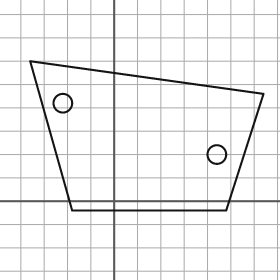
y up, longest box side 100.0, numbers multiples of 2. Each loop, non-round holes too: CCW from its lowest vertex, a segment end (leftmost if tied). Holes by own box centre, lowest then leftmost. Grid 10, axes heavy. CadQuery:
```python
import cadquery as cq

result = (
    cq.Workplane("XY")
    .moveTo(-18.0, -4.0)
    .lineTo(48.0, -4.0)
    .lineTo(64.0, 46.0)
    .lineTo(-36.0, 60.0)
    .close()
    .moveTo(44.0, 20.0)
    .circle(4.0)
    .moveTo(-22.0, 42.0)
    .circle(4.0)
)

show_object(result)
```